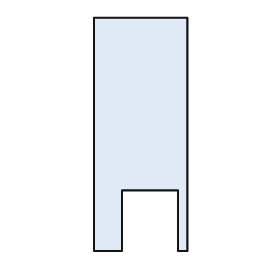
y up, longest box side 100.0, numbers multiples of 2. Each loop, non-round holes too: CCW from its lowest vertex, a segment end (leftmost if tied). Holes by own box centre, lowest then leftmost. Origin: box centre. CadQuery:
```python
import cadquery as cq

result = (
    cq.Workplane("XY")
    .moveTo(-20.0, -50.0)
    .lineTo(-8.0, -50.0)
    .lineTo(-8.0, -24.0)
    .lineTo(16.0, -24.0)
    .lineTo(16.0, -50.0)
    .lineTo(20.0, -50.0)
    .lineTo(20.0, 50.0)
    .lineTo(-20.0, 50.0)
    .close()
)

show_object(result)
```